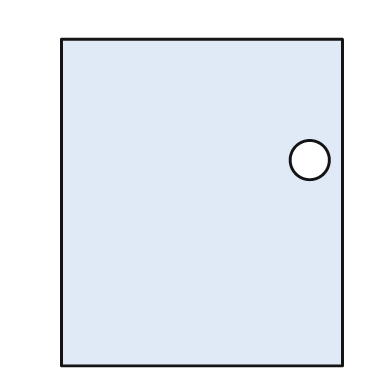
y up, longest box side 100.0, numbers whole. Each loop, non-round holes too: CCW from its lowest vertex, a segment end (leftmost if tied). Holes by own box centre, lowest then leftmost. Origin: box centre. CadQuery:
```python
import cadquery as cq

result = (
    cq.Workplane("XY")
    .moveTo(-43.0, -50.0)
    .lineTo(43.0, -50.0)
    .lineTo(43.0, 50.0)
    .lineTo(-43.0, 50.0)
    .close()
    .moveTo(33.0, 13.0)
    .circle(6.0)
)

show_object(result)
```